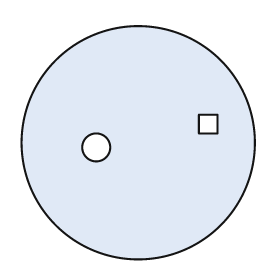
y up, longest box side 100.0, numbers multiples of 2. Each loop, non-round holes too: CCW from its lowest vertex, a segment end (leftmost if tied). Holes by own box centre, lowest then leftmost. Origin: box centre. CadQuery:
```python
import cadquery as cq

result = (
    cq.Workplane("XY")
    .moveTo(0.0, 0.0)
    .circle(50.0)
    .moveTo(-18.0, -2.0)
    .circle(6.0)
    .moveTo(26.0, 4.0)
    .lineTo(34.0, 4.0)
    .lineTo(34.0, 12.0)
    .lineTo(26.0, 12.0)
    .close()
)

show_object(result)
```